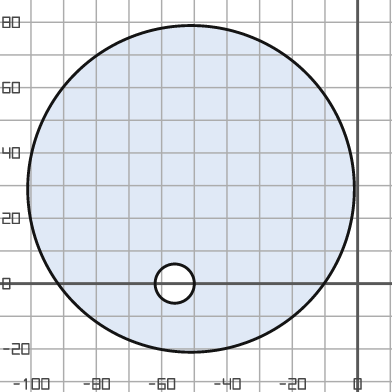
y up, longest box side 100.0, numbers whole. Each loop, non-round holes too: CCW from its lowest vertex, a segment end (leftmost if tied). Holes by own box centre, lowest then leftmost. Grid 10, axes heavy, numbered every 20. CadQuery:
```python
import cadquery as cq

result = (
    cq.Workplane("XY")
    .moveTo(-51.0, 29.0)
    .circle(50.0)
    .moveTo(-56.0, 0.0)
    .circle(6.0)
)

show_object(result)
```